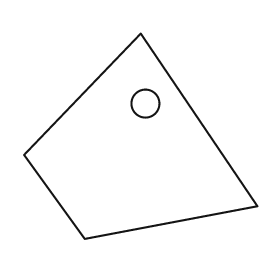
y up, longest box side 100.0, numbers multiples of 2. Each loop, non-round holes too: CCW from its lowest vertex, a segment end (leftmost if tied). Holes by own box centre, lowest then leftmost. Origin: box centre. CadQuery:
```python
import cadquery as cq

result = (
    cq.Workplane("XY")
    .moveTo(-24.0, -44.0)
    .lineTo(50.0, -30.0)
    .lineTo(0.0, 44.0)
    .lineTo(-50.0, -8.0)
    .close()
    .moveTo(2.0, 14.0)
    .circle(6.0)
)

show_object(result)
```